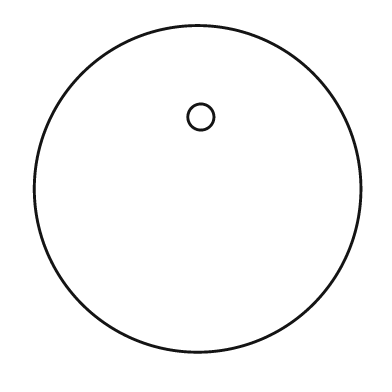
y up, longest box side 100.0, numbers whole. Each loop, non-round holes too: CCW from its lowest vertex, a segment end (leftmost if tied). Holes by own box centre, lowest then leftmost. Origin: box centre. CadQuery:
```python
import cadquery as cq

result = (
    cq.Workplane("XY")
    .moveTo(0.0, 0.0)
    .circle(50.0)
    .moveTo(1.0, 22.0)
    .circle(4.0)
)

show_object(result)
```